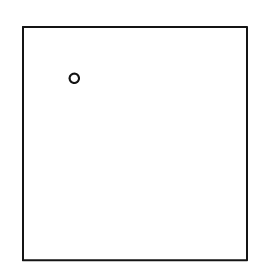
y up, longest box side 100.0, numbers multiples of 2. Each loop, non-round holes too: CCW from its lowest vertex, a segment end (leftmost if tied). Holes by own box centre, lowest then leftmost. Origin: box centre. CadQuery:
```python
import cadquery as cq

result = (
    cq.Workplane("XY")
    .moveTo(-48.0, -50.0)
    .lineTo(48.0, -50.0)
    .lineTo(48.0, 50.0)
    .lineTo(-48.0, 50.0)
    .close()
    .moveTo(-26.0, 28.0)
    .circle(2.0)
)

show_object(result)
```